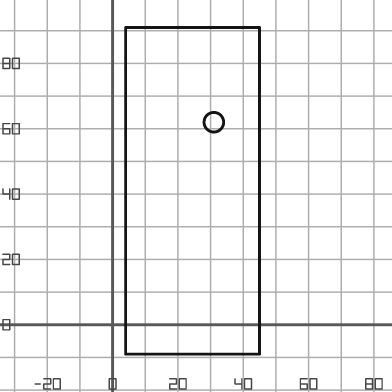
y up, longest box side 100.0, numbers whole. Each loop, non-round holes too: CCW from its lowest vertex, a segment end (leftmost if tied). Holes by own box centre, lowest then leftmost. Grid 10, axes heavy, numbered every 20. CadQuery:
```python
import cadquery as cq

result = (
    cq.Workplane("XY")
    .moveTo(4.0, -9.0)
    .lineTo(45.0, -9.0)
    .lineTo(45.0, 91.0)
    .lineTo(4.0, 91.0)
    .close()
    .moveTo(31.0, 62.0)
    .circle(3.0)
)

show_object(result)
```